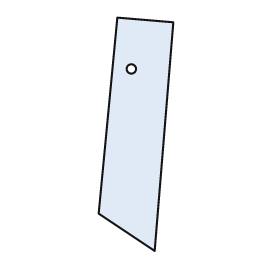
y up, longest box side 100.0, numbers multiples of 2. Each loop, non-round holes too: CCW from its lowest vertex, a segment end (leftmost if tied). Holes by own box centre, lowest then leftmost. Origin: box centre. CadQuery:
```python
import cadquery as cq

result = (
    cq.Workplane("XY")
    .moveTo(8.0, -50.0)
    .lineTo(16.0, 48.0)
    .lineTo(-8.0, 50.0)
    .lineTo(-16.0, -34.0)
    .close()
    .moveTo(-2.0, 28.0)
    .circle(2.0)
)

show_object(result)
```